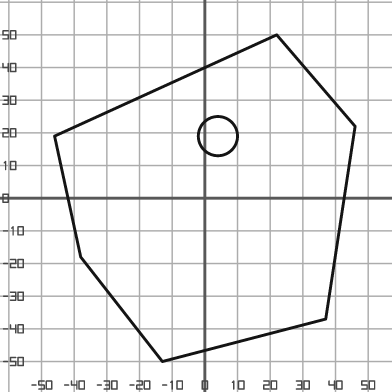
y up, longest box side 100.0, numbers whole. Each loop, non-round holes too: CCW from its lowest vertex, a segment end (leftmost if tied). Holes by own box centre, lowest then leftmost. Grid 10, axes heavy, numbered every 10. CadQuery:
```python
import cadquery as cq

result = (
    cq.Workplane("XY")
    .moveTo(-13.0, -50.0)
    .lineTo(37.0, -37.0)
    .lineTo(46.0, 22.0)
    .lineTo(22.0, 50.0)
    .lineTo(-46.0, 19.0)
    .lineTo(-38.0, -18.0)
    .close()
    .moveTo(4.0, 19.0)
    .circle(6.0)
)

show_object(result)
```